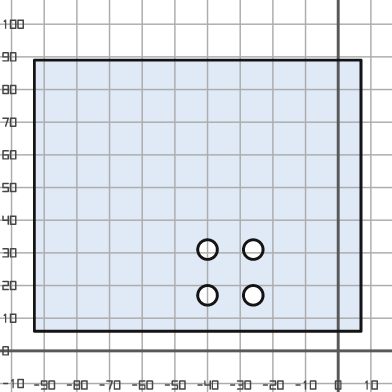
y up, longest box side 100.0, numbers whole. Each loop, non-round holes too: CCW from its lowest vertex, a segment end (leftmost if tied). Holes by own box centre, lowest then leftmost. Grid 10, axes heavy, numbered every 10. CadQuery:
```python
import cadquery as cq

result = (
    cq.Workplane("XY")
    .moveTo(-93.0, 6.0)
    .lineTo(7.0, 6.0)
    .lineTo(7.0, 89.0)
    .lineTo(-93.0, 89.0)
    .close()
    .moveTo(-40.0, 17.0)
    .circle(3.0)
    .moveTo(-26.0, 17.0)
    .circle(3.0)
    .moveTo(-40.0, 31.0)
    .circle(3.0)
    .moveTo(-26.0, 31.0)
    .circle(3.0)
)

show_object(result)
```